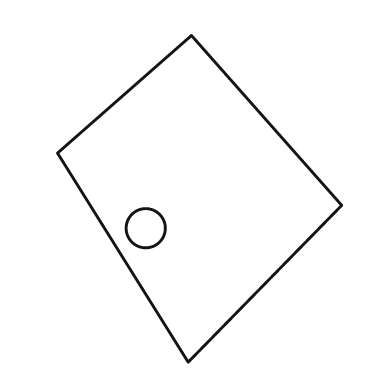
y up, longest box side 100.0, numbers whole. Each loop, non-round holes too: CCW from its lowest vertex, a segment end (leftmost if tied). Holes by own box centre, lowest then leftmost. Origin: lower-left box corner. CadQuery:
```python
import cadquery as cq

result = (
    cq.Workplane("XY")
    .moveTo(40.0, 0.0)
    .lineTo(87.0, 48.0)
    .lineTo(41.0, 100.0)
    .lineTo(0.0, 64.0)
    .close()
    .moveTo(27.0, 41.0)
    .circle(6.0)
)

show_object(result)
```